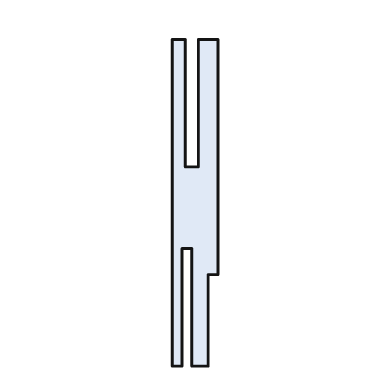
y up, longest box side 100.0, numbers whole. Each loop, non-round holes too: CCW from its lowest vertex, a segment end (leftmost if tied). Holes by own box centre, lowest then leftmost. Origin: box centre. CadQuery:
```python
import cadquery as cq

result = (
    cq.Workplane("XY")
    .moveTo(-7.0, -50.0)
    .lineTo(-4.0, -50.0)
    .lineTo(-4.0, -14.0)
    .lineTo(-1.0, -14.0)
    .lineTo(-1.0, -50.0)
    .lineTo(4.0, -50.0)
    .lineTo(4.0, -22.0)
    .lineTo(7.0, -22.0)
    .lineTo(7.0, 50.0)
    .lineTo(1.0, 50.0)
    .lineTo(1.0, 11.0)
    .lineTo(-3.0, 11.0)
    .lineTo(-3.0, 50.0)
    .lineTo(-7.0, 50.0)
    .close()
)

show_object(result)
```